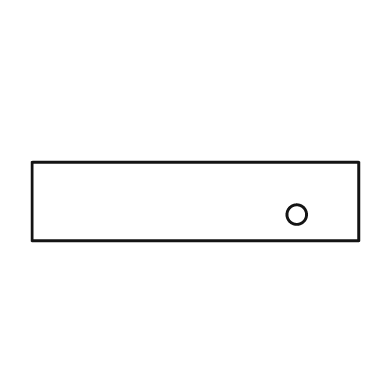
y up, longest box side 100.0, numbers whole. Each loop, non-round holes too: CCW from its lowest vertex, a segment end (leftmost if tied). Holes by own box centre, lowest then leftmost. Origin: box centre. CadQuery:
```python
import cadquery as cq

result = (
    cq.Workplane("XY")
    .moveTo(-50.0, -12.0)
    .lineTo(50.0, -12.0)
    .lineTo(50.0, 12.0)
    .lineTo(-50.0, 12.0)
    .close()
    .moveTo(31.0, -4.0)
    .circle(3.0)
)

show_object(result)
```